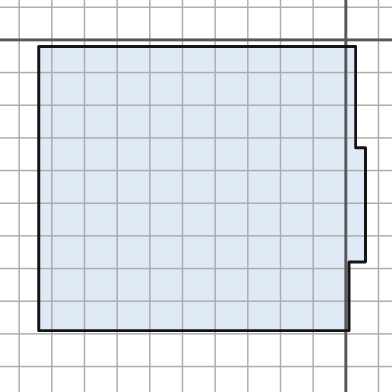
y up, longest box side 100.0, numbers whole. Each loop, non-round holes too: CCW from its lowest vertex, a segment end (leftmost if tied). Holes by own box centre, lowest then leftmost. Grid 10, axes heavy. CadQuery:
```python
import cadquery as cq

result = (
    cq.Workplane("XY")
    .moveTo(-94.0, -89.0)
    .lineTo(1.0, -89.0)
    .lineTo(1.0, -68.0)
    .lineTo(6.0, -68.0)
    .lineTo(6.0, -33.0)
    .lineTo(3.0, -33.0)
    .lineTo(3.0, -2.0)
    .lineTo(-94.0, -2.0)
    .close()
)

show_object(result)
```